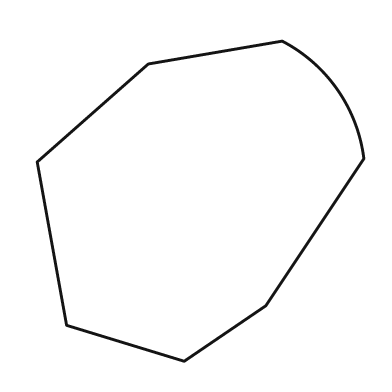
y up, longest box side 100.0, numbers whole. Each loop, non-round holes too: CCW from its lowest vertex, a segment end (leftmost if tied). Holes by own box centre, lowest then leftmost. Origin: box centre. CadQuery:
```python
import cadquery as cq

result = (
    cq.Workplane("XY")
    .moveTo(-5.0, -49.0)
    .lineTo(20.0, -32.0)
    .lineTo(50.0, 13.0)
    .threePointArc((42.0, 34.0), (25.0, 49.0))
    .lineTo(-16.0, 42.0)
    .lineTo(-50.0, 12.0)
    .lineTo(-41.0, -38.0)
    .close()
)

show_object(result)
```